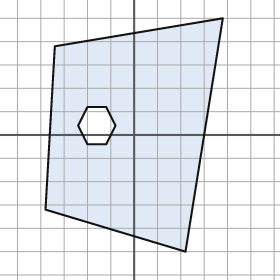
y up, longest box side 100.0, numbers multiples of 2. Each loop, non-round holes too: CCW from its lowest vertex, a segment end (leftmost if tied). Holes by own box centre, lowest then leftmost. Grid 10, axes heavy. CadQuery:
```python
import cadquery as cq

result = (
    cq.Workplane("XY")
    .moveTo(22.0, -50.0)
    .lineTo(38.0, 50.0)
    .lineTo(-34.0, 38.0)
    .lineTo(-38.0, -32.0)
    .close()
    .moveTo(-20.0, -4.0)
    .lineTo(-12.0, -4.0)
    .lineTo(-8.0, 4.0)
    .lineTo(-12.0, 12.0)
    .lineTo(-20.0, 12.0)
    .lineTo(-24.0, 4.0)
    .close()
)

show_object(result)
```